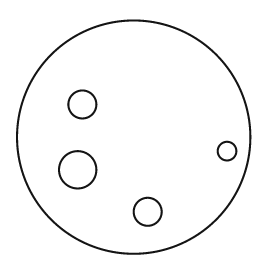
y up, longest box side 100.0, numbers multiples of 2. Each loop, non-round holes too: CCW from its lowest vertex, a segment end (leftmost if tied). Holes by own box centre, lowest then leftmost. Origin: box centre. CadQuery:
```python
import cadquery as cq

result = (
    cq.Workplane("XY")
    .moveTo(0.0, 0.0)
    .circle(50.0)
    .moveTo(6.0, -32.0)
    .circle(6.0)
    .moveTo(-24.0, -14.0)
    .circle(8.0)
    .moveTo(40.0, -6.0)
    .circle(4.0)
    .moveTo(-22.0, 14.0)
    .circle(6.0)
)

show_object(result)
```